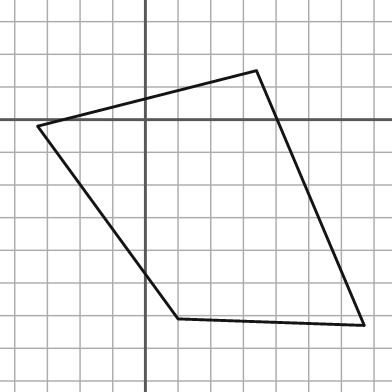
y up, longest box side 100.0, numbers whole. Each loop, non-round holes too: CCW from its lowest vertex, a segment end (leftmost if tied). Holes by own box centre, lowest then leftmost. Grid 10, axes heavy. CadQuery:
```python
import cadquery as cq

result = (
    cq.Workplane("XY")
    .moveTo(67.0, -63.0)
    .lineTo(34.0, 15.0)
    .lineTo(-33.0, -2.0)
    .lineTo(10.0, -61.0)
    .close()
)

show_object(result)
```